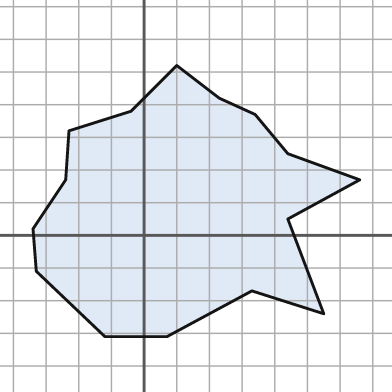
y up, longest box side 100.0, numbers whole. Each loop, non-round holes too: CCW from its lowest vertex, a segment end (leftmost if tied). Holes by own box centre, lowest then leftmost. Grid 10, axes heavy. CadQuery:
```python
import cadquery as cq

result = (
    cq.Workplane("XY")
    .moveTo(-12.0, -31.0)
    .lineTo(7.0, -31.0)
    .lineTo(33.0, -17.0)
    .lineTo(55.0, -24.0)
    .lineTo(44.0, 5.0)
    .lineTo(66.0, 17.0)
    .lineTo(44.0, 25.0)
    .lineTo(34.0, 37.0)
    .lineTo(23.0, 42.0)
    .lineTo(10.0, 52.0)
    .lineTo(-4.0, 38.0)
    .lineTo(-23.0, 32.0)
    .lineTo(-24.0, 17.0)
    .lineTo(-34.0, 2.0)
    .lineTo(-33.0, -11.0)
    .close()
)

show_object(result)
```